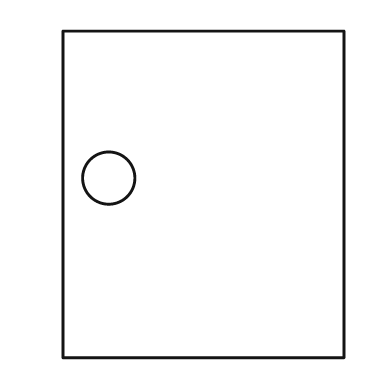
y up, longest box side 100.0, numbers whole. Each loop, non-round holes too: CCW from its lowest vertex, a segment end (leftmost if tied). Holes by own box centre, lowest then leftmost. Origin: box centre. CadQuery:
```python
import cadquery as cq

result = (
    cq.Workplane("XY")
    .moveTo(-43.0, -50.0)
    .lineTo(43.0, -50.0)
    .lineTo(43.0, 50.0)
    .lineTo(-43.0, 50.0)
    .close()
    .moveTo(-29.0, 5.0)
    .circle(8.0)
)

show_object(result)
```